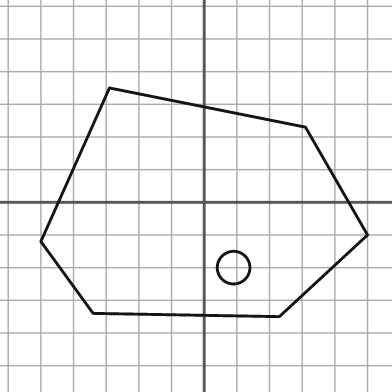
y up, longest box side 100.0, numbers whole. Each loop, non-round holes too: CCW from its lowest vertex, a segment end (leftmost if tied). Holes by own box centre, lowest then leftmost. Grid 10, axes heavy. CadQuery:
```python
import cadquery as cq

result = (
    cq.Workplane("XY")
    .moveTo(23.0, -35.0)
    .lineTo(50.0, -10.0)
    .lineTo(31.0, 23.0)
    .lineTo(-29.0, 35.0)
    .lineTo(-50.0, -12.0)
    .lineTo(-34.0, -34.0)
    .close()
    .moveTo(9.0, -20.0)
    .circle(5.0)
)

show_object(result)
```